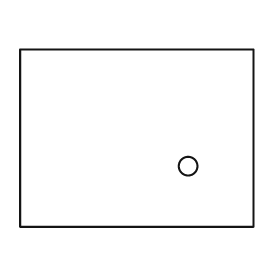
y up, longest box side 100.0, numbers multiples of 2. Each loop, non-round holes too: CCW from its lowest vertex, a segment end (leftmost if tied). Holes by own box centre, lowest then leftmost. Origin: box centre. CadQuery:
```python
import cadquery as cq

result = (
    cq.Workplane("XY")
    .moveTo(-50.0, -38.0)
    .lineTo(50.0, -38.0)
    .lineTo(50.0, 38.0)
    .lineTo(-50.0, 38.0)
    .close()
    .moveTo(22.0, -12.0)
    .circle(4.0)
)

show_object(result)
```